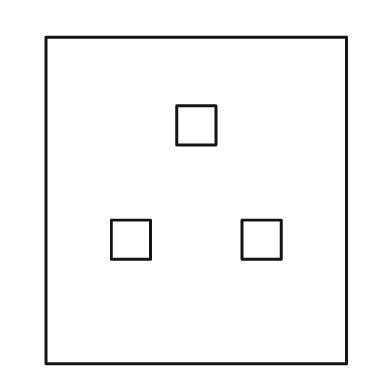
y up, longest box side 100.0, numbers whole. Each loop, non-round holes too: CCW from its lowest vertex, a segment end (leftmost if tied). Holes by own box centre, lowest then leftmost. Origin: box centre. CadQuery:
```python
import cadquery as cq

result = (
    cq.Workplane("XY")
    .moveTo(-46.0, -50.0)
    .lineTo(46.0, -50.0)
    .lineTo(46.0, 50.0)
    .lineTo(-46.0, 50.0)
    .close()
    .moveTo(-26.0, -18.0)
    .lineTo(-14.0, -18.0)
    .lineTo(-14.0, -6.0)
    .lineTo(-26.0, -6.0)
    .close()
    .moveTo(14.0, -18.0)
    .lineTo(26.0, -18.0)
    .lineTo(26.0, -6.0)
    .lineTo(14.0, -6.0)
    .close()
    .moveTo(-6.0, 17.0)
    .lineTo(6.0, 17.0)
    .lineTo(6.0, 29.0)
    .lineTo(-6.0, 29.0)
    .close()
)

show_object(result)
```